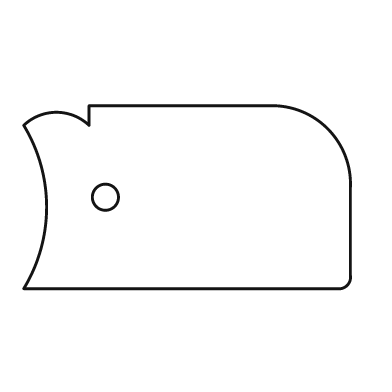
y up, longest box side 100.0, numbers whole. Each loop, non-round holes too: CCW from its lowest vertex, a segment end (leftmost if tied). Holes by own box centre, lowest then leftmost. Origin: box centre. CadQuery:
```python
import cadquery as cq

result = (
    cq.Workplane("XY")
    .moveTo(-50.0, -28.0)
    .lineTo(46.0, -28.0)
    .threePointArc((49.0, -27.0), (50.0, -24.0))
    .lineTo(50.0, 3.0)
    .threePointArc((43.0, 21.0), (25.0, 28.0))
    .lineTo(-30.0, 28.0)
    .lineTo(-30.0, 22.0)
    .threePointArc((-40.0, 26.0), (-50.0, 22.0))
    .threePointArc((-43.0, -3.0), (-50.0, -28.0))
    .close()
    .moveTo(-25.0, 0.0)
    .circle(4.0)
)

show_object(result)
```